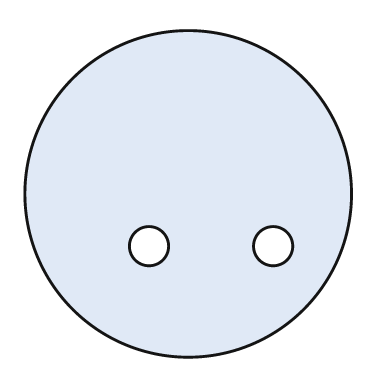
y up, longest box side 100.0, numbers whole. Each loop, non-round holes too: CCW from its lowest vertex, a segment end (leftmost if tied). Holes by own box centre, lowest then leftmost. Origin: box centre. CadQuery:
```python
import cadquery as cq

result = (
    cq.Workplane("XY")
    .moveTo(0.0, 0.0)
    .circle(50.0)
    .moveTo(-12.0, -16.0)
    .circle(6.0)
    .moveTo(26.0, -16.0)
    .circle(6.0)
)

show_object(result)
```